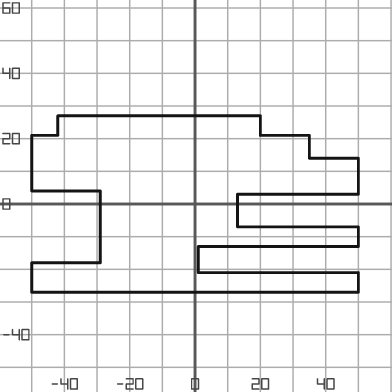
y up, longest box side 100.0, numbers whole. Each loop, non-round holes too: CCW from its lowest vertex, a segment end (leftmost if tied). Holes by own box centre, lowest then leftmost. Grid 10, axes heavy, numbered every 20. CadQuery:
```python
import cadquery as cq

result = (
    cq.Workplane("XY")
    .moveTo(-50.0, -27.0)
    .lineTo(50.0, -27.0)
    .lineTo(50.0, -21.0)
    .lineTo(1.0, -21.0)
    .lineTo(1.0, -13.0)
    .lineTo(50.0, -13.0)
    .lineTo(50.0, -7.0)
    .lineTo(13.0, -7.0)
    .lineTo(13.0, 3.0)
    .lineTo(50.0, 3.0)
    .lineTo(50.0, 14.0)
    .lineTo(35.0, 14.0)
    .lineTo(35.0, 21.0)
    .lineTo(20.0, 21.0)
    .lineTo(20.0, 27.0)
    .lineTo(-42.0, 27.0)
    .lineTo(-42.0, 21.0)
    .lineTo(-50.0, 21.0)
    .lineTo(-50.0, 4.0)
    .lineTo(-29.0, 4.0)
    .lineTo(-29.0, -18.0)
    .lineTo(-50.0, -18.0)
    .close()
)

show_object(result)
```